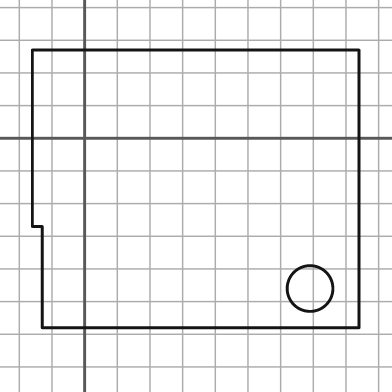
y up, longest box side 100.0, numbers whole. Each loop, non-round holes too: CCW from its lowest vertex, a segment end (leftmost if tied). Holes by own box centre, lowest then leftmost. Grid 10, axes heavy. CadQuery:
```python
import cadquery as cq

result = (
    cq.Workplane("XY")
    .moveTo(-13.0, -58.0)
    .lineTo(84.0, -58.0)
    .lineTo(84.0, 27.0)
    .lineTo(-16.0, 27.0)
    .lineTo(-16.0, -27.0)
    .lineTo(-13.0, -27.0)
    .close()
    .moveTo(69.0, -46.0)
    .circle(7.0)
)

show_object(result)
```